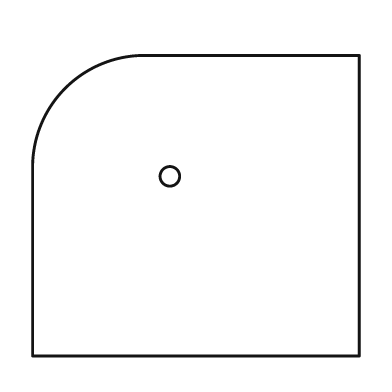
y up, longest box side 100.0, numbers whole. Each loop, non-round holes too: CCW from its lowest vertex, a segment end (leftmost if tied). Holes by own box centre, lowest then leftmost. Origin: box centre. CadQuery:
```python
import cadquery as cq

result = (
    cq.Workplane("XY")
    .moveTo(-50.0, -46.0)
    .lineTo(50.0, -46.0)
    .lineTo(50.0, 46.0)
    .lineTo(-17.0, 46.0)
    .threePointArc((-40.0, 36.0), (-50.0, 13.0))
    .close()
    .moveTo(-8.0, 9.0)
    .circle(3.0)
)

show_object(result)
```